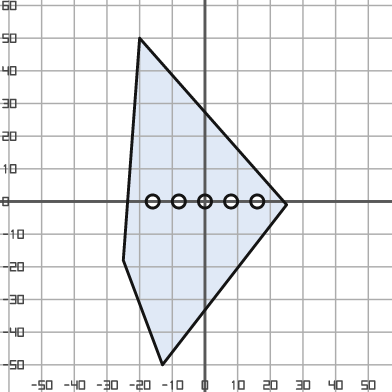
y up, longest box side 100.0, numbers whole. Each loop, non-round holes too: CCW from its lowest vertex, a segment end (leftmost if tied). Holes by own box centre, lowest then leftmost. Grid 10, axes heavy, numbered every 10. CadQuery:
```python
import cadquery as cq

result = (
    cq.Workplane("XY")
    .moveTo(-13.0, -50.0)
    .lineTo(25.0, -1.0)
    .lineTo(-20.0, 50.0)
    .lineTo(-25.0, -18.0)
    .close()
    .moveTo(-16.0, 0.0)
    .circle(2.0)
    .moveTo(-8.0, 0.0)
    .circle(2.0)
    .moveTo(0.0, 0.0)
    .circle(2.0)
    .moveTo(8.0, 0.0)
    .circle(2.0)
    .moveTo(16.0, 0.0)
    .circle(2.0)
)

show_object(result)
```